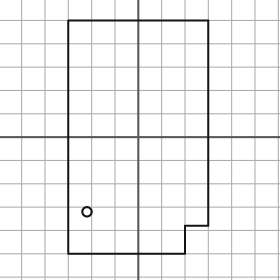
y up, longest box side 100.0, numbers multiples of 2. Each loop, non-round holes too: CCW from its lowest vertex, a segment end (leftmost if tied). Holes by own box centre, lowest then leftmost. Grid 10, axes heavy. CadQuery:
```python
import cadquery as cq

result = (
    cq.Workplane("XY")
    .moveTo(-30.0, -50.0)
    .lineTo(20.0, -50.0)
    .lineTo(20.0, -38.0)
    .lineTo(30.0, -38.0)
    .lineTo(30.0, 50.0)
    .lineTo(-30.0, 50.0)
    .close()
    .moveTo(-22.0, -32.0)
    .circle(2.0)
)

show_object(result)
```